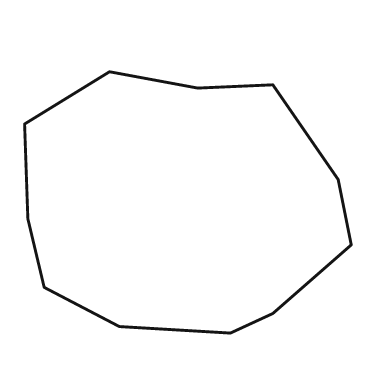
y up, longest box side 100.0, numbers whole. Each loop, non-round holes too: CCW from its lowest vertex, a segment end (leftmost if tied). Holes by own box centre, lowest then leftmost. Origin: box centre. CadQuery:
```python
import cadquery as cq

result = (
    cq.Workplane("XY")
    .moveTo(13.0, -40.0)
    .lineTo(26.0, -34.0)
    .lineTo(50.0, -13.0)
    .lineTo(46.0, 7.0)
    .lineTo(26.0, 36.0)
    .lineTo(3.0, 35.0)
    .lineTo(-24.0, 40.0)
    .lineTo(-50.0, 24.0)
    .lineTo(-49.0, -5.0)
    .lineTo(-44.0, -26.0)
    .lineTo(-21.0, -38.0)
    .close()
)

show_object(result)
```